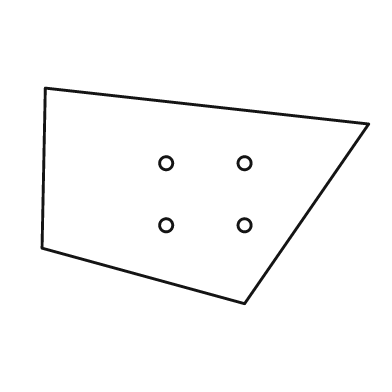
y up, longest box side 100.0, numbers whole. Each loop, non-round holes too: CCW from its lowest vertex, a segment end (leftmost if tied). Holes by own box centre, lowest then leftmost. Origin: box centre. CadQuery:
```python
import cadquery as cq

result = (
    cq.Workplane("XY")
    .moveTo(12.0, -33.0)
    .lineTo(50.0, 22.0)
    .lineTo(-49.0, 33.0)
    .lineTo(-50.0, -16.0)
    .close()
    .moveTo(-12.0, -9.0)
    .circle(2.0)
    .moveTo(12.0, -9.0)
    .circle(2.0)
    .moveTo(-12.0, 10.0)
    .circle(2.0)
    .moveTo(12.0, 10.0)
    .circle(2.0)
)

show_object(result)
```